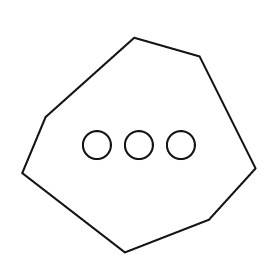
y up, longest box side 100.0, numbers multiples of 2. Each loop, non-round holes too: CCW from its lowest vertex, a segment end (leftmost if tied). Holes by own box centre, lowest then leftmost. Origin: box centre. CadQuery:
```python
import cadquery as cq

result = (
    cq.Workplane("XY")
    .moveTo(-6.0, -46.0)
    .lineTo(30.0, -32.0)
    .lineTo(50.0, -10.0)
    .lineTo(26.0, 38.0)
    .lineTo(-2.0, 46.0)
    .lineTo(-40.0, 12.0)
    .lineTo(-50.0, -12.0)
    .close()
    .moveTo(-18.0, 0.0)
    .circle(6.0)
    .moveTo(0.0, 0.0)
    .circle(6.0)
    .moveTo(18.0, 0.0)
    .circle(6.0)
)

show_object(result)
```